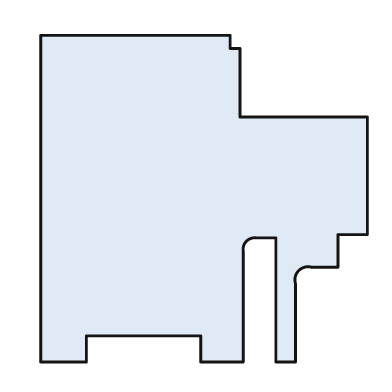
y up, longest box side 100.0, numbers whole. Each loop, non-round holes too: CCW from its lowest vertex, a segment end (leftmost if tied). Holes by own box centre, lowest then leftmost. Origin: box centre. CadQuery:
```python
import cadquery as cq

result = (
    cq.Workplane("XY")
    .moveTo(-50.0, -50.0)
    .lineTo(-36.0, -50.0)
    .lineTo(-36.0, -42.0)
    .lineTo(-1.0, -42.0)
    .lineTo(-1.0, -50.0)
    .lineTo(12.0, -50.0)
    .lineTo(12.0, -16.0)
    .threePointArc((13.0, -13.0), (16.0, -12.0))
    .lineTo(22.0, -12.0)
    .lineTo(22.0, -50.0)
    .lineTo(28.0, -50.0)
    .lineTo(28.0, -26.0)
    .threePointArc((29.0, -22.0), (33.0, -21.0))
    .lineTo(41.0, -21.0)
    .lineTo(41.0, -11.0)
    .lineTo(50.0, -11.0)
    .lineTo(50.0, 25.0)
    .lineTo(11.0, 25.0)
    .lineTo(11.0, 46.0)
    .lineTo(8.0, 46.0)
    .lineTo(8.0, 50.0)
    .lineTo(-50.0, 50.0)
    .close()
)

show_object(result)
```